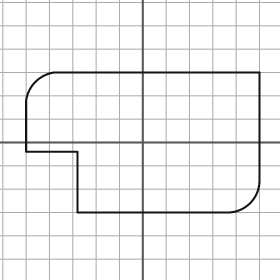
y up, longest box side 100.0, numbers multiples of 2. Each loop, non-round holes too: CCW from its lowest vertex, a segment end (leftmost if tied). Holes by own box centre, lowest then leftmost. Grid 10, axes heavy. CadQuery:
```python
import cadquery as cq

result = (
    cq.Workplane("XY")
    .moveTo(-28.0, -30.0)
    .lineTo(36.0, -30.0)
    .threePointArc((46.0, -26.0), (50.0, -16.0))
    .lineTo(50.0, 30.0)
    .lineTo(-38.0, 30.0)
    .threePointArc((-46.0, 26.0), (-50.0, 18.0))
    .lineTo(-50.0, -4.0)
    .lineTo(-28.0, -4.0)
    .close()
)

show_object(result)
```